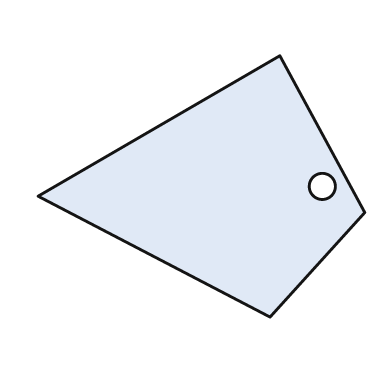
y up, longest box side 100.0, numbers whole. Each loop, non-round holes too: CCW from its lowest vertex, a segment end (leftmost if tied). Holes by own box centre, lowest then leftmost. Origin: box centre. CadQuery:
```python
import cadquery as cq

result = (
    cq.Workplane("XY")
    .moveTo(21.0, -40.0)
    .lineTo(50.0, -8.0)
    .lineTo(24.0, 40.0)
    .lineTo(-50.0, -3.0)
    .close()
    .moveTo(37.0, 0.0)
    .circle(4.0)
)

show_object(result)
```